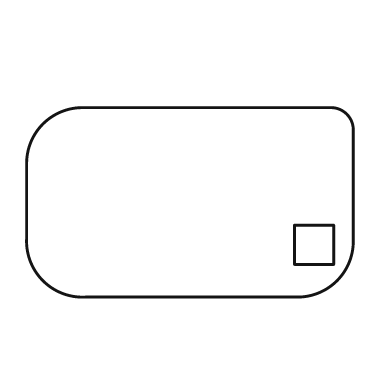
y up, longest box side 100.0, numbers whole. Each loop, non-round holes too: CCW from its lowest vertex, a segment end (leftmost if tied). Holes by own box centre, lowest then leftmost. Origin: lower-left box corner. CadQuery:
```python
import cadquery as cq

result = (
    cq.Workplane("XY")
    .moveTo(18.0, 0.0)
    .lineTo(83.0, 0.0)
    .threePointArc((95.0, 5.0), (100.0, 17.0))
    .lineTo(100.0, 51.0)
    .threePointArc((98.0, 56.0), (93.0, 58.0))
    .lineTo(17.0, 58.0)
    .threePointArc((5.0, 53.0), (0.0, 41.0))
    .lineTo(0.0, 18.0)
    .threePointArc((5.0, 5.0), (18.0, 0.0))
    .close()
    .moveTo(82.0, 10.0)
    .lineTo(94.0, 10.0)
    .lineTo(94.0, 22.0)
    .lineTo(82.0, 22.0)
    .close()
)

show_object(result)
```